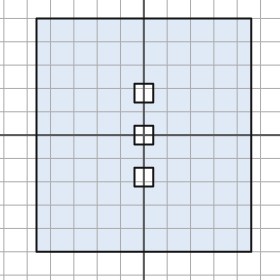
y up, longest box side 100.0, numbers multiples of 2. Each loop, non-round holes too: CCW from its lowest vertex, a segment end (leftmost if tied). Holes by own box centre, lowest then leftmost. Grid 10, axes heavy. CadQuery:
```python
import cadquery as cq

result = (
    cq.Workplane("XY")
    .moveTo(-46.0, -50.0)
    .lineTo(46.0, -50.0)
    .lineTo(46.0, 50.0)
    .lineTo(-46.0, 50.0)
    .close()
    .moveTo(-4.0, -22.0)
    .lineTo(4.0, -22.0)
    .lineTo(4.0, -14.0)
    .lineTo(-4.0, -14.0)
    .close()
    .moveTo(-4.0, -4.0)
    .lineTo(4.0, -4.0)
    .lineTo(4.0, 4.0)
    .lineTo(-4.0, 4.0)
    .close()
    .moveTo(-4.0, 14.0)
    .lineTo(4.0, 14.0)
    .lineTo(4.0, 22.0)
    .lineTo(-4.0, 22.0)
    .close()
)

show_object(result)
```